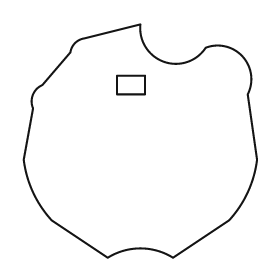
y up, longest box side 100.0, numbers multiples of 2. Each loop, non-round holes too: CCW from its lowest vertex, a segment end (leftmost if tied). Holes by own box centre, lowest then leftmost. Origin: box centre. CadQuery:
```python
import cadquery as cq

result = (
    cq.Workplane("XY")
    .moveTo(-14.0, -50.0)
    .threePointArc((0.0, -46.0), (14.0, -50.0))
    .lineTo(38.0, -34.0)
    .threePointArc((46.0, -22.0), (50.0, -8.0))
    .lineTo(46.0, 20.0)
    .threePointArc((44.0, 36.0), (28.0, 40.0))
    .threePointArc((10.0, 34.0), (0.0, 50.0))
    .lineTo(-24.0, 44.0)
    .threePointArc((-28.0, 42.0), (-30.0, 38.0))
    .lineTo(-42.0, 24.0)
    .threePointArc((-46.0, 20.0), (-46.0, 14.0))
    .lineTo(-50.0, -8.0)
    .threePointArc((-46.0, -22.0), (-38.0, -34.0))
    .close()
    .moveTo(-10.0, 20.0)
    .lineTo(2.0, 20.0)
    .lineTo(2.0, 28.0)
    .lineTo(-10.0, 28.0)
    .close()
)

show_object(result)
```